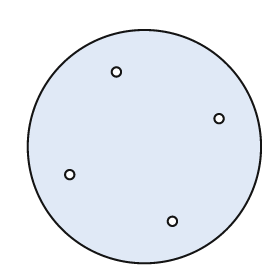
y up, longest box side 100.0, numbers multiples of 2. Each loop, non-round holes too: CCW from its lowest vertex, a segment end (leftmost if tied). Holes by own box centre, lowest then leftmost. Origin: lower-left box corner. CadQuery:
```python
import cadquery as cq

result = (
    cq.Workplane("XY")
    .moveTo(50.0, 50.0)
    .circle(50.0)
    .moveTo(62.0, 18.0)
    .circle(2.0)
    .moveTo(18.0, 38.0)
    .circle(2.0)
    .moveTo(82.0, 62.0)
    .circle(2.0)
    .moveTo(38.0, 82.0)
    .circle(2.0)
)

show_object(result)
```